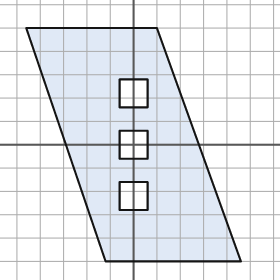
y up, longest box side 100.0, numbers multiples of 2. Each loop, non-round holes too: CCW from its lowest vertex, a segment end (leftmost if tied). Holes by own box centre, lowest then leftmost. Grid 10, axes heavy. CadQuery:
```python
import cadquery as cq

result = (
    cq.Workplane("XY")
    .moveTo(-12.0, -50.0)
    .lineTo(46.0, -50.0)
    .lineTo(10.0, 50.0)
    .lineTo(-46.0, 50.0)
    .close()
    .moveTo(-6.0, -28.0)
    .lineTo(6.0, -28.0)
    .lineTo(6.0, -16.0)
    .lineTo(-6.0, -16.0)
    .close()
    .moveTo(-6.0, -6.0)
    .lineTo(6.0, -6.0)
    .lineTo(6.0, 6.0)
    .lineTo(-6.0, 6.0)
    .close()
    .moveTo(-6.0, 16.0)
    .lineTo(6.0, 16.0)
    .lineTo(6.0, 28.0)
    .lineTo(-6.0, 28.0)
    .close()
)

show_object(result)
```